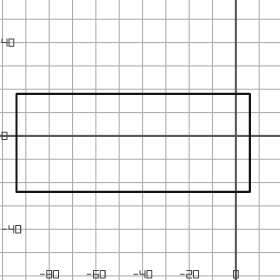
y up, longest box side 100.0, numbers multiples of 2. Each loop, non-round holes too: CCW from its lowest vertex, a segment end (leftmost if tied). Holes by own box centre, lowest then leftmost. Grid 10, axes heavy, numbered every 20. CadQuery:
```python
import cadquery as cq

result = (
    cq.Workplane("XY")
    .moveTo(-94.0, -24.0)
    .lineTo(6.0, -24.0)
    .lineTo(6.0, 18.0)
    .lineTo(-94.0, 18.0)
    .close()
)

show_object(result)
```